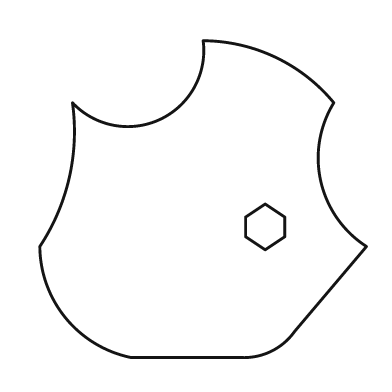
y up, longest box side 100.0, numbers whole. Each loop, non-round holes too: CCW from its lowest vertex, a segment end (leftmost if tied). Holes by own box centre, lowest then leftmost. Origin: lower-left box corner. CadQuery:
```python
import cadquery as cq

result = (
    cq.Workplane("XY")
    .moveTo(28.0, 0.0)
    .lineTo(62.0, 0.0)
    .threePointArc((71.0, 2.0), (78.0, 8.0))
    .lineTo(100.0, 34.0)
    .threePointArc((86.0, 54.0), (90.0, 78.0))
    .threePointArc((72.0, 92.0), (50.0, 97.0))
    .threePointArc((37.0, 73.0), (10.0, 78.0))
    .threePointArc((9.0, 55.0), (0.0, 34.0))
    .threePointArc((8.0, 12.0), (28.0, 0.0))
    .close()
    .moveTo(69.0, 33.0)
    .lineTo(75.0, 37.0)
    .lineTo(75.0, 43.0)
    .lineTo(69.0, 47.0)
    .lineTo(63.0, 43.0)
    .lineTo(63.0, 37.0)
    .close()
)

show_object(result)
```